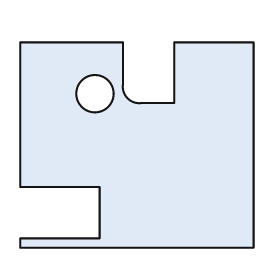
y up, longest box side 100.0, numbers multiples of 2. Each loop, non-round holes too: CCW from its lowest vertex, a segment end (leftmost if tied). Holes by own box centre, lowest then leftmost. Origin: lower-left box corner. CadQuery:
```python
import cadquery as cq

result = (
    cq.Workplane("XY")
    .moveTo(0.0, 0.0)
    .lineTo(100.0, 0.0)
    .lineTo(100.0, 88.0)
    .lineTo(66.0, 88.0)
    .lineTo(66.0, 62.0)
    .lineTo(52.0, 62.0)
    .threePointArc((46.0, 64.0), (44.0, 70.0))
    .lineTo(44.0, 88.0)
    .lineTo(0.0, 88.0)
    .lineTo(0.0, 26.0)
    .lineTo(34.0, 26.0)
    .lineTo(34.0, 4.0)
    .lineTo(0.0, 4.0)
    .close()
    .moveTo(32.0, 66.0)
    .circle(8.0)
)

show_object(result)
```